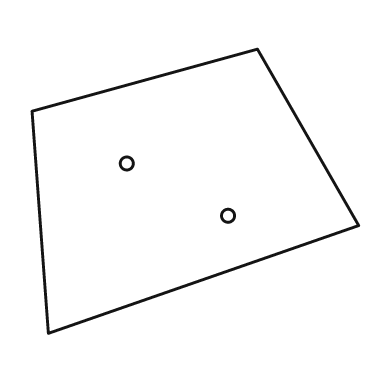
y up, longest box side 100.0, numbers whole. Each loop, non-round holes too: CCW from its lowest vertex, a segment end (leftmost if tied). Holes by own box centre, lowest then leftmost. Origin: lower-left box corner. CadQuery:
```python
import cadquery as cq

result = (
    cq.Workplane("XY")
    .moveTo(5.0, 0.0)
    .lineTo(100.0, 33.0)
    .lineTo(69.0, 87.0)
    .lineTo(0.0, 68.0)
    .close()
    .moveTo(60.0, 36.0)
    .circle(2.0)
    .moveTo(29.0, 52.0)
    .circle(2.0)
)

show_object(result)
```